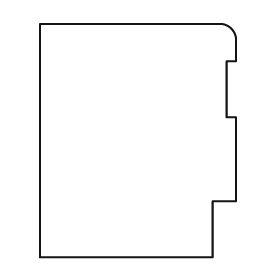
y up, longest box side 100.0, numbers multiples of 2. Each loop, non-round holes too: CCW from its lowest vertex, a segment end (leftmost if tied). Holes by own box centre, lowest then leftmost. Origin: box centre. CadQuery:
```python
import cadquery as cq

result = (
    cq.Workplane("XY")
    .moveTo(-42.0, -50.0)
    .lineTo(32.0, -50.0)
    .lineTo(32.0, -26.0)
    .lineTo(42.0, -26.0)
    .lineTo(42.0, 10.0)
    .lineTo(38.0, 10.0)
    .lineTo(38.0, 34.0)
    .lineTo(42.0, 34.0)
    .lineTo(42.0, 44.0)
    .threePointArc((40.0, 48.0), (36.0, 50.0))
    .lineTo(-42.0, 50.0)
    .close()
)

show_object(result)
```